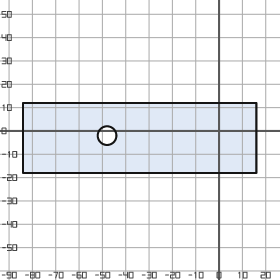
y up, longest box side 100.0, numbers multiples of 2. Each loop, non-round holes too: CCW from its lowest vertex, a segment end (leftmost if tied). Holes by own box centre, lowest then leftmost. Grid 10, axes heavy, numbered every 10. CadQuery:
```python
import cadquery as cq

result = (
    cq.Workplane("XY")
    .moveTo(-84.0, -18.0)
    .lineTo(16.0, -18.0)
    .lineTo(16.0, 12.0)
    .lineTo(-84.0, 12.0)
    .close()
    .moveTo(-48.0, -2.0)
    .circle(4.0)
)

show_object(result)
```